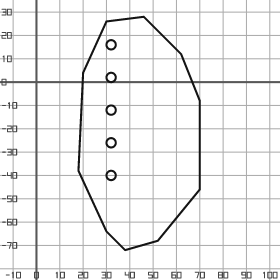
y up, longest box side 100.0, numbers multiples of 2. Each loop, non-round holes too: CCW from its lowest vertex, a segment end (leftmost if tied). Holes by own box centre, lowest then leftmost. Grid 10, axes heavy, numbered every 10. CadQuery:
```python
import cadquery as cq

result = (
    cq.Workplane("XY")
    .moveTo(38.0, -72.0)
    .lineTo(52.0, -68.0)
    .lineTo(70.0, -46.0)
    .lineTo(70.0, -8.0)
    .lineTo(62.0, 12.0)
    .lineTo(46.0, 28.0)
    .lineTo(30.0, 26.0)
    .lineTo(20.0, 4.0)
    .lineTo(18.0, -38.0)
    .lineTo(30.0, -64.0)
    .close()
    .moveTo(32.0, -40.0)
    .circle(2.0)
    .moveTo(32.0, -26.0)
    .circle(2.0)
    .moveTo(32.0, -12.0)
    .circle(2.0)
    .moveTo(32.0, 2.0)
    .circle(2.0)
    .moveTo(32.0, 16.0)
    .circle(2.0)
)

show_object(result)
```